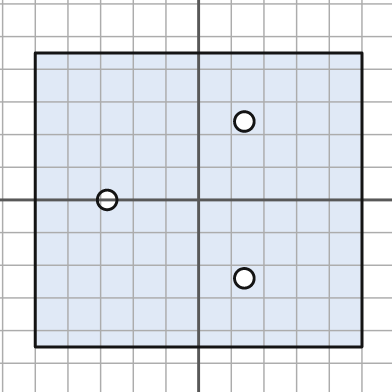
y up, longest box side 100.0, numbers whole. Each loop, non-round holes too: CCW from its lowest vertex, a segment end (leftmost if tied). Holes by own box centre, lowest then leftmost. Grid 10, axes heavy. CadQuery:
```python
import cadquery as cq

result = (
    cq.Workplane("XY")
    .moveTo(-50.0, -45.0)
    .lineTo(50.0, -45.0)
    .lineTo(50.0, 45.0)
    .lineTo(-50.0, 45.0)
    .close()
    .moveTo(14.0, -24.0)
    .circle(3.0)
    .moveTo(-28.0, 0.0)
    .circle(3.0)
    .moveTo(14.0, 24.0)
    .circle(3.0)
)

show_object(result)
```